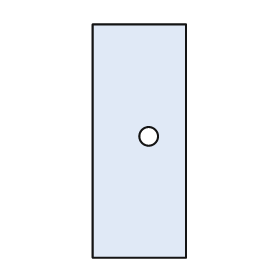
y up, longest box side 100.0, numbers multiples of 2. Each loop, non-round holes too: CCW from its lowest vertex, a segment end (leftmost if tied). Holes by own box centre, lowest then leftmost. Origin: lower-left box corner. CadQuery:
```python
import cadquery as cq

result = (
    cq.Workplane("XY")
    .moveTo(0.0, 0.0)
    .lineTo(40.0, 0.0)
    .lineTo(40.0, 100.0)
    .lineTo(0.0, 100.0)
    .close()
    .moveTo(24.0, 52.0)
    .circle(4.0)
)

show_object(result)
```